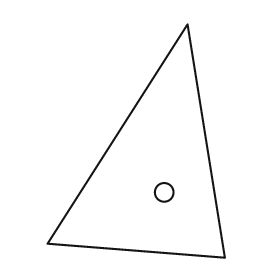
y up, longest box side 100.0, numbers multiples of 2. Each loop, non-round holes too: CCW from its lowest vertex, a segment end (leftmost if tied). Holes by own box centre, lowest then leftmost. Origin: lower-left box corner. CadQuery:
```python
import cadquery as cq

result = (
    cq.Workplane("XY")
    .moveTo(76.0, 0.0)
    .lineTo(60.0, 100.0)
    .lineTo(0.0, 6.0)
    .close()
    .moveTo(50.0, 28.0)
    .circle(4.0)
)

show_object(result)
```